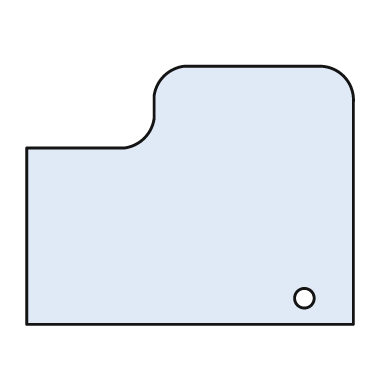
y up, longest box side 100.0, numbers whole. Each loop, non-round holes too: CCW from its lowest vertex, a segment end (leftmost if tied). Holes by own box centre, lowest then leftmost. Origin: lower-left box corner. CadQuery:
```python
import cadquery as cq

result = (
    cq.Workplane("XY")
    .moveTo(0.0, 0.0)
    .lineTo(100.0, 0.0)
    .lineTo(100.0, 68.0)
    .threePointArc((97.0, 76.0), (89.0, 79.0))
    .lineTo(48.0, 79.0)
    .threePointArc((42.0, 76.0), (39.0, 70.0))
    .lineTo(39.0, 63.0)
    .threePointArc((36.0, 57.0), (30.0, 54.0))
    .lineTo(0.0, 54.0)
    .close()
    .moveTo(85.0, 8.0)
    .circle(3.0)
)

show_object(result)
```